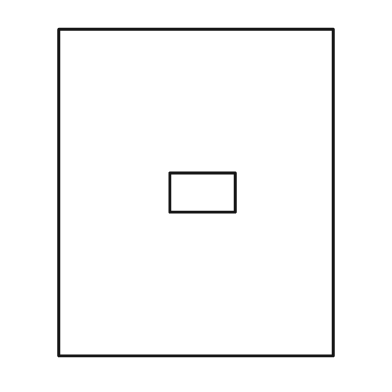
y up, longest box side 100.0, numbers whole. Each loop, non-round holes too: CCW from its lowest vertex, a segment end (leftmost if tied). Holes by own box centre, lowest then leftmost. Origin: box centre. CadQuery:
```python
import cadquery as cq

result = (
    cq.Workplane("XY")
    .moveTo(-42.0, -50.0)
    .lineTo(42.0, -50.0)
    .lineTo(42.0, 50.0)
    .lineTo(-42.0, 50.0)
    .close()
    .moveTo(-8.0, -6.0)
    .lineTo(12.0, -6.0)
    .lineTo(12.0, 6.0)
    .lineTo(-8.0, 6.0)
    .close()
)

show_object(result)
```